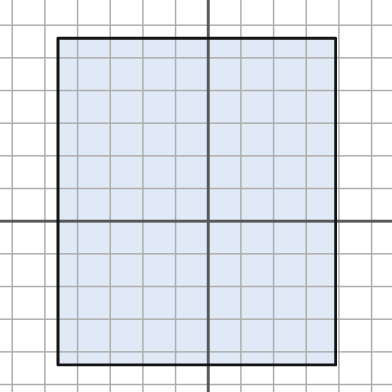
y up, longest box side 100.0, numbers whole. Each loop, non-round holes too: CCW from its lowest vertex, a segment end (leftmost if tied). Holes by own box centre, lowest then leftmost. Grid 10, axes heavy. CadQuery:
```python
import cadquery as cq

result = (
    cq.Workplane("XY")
    .moveTo(-46.0, -44.0)
    .lineTo(39.0, -44.0)
    .lineTo(39.0, 56.0)
    .lineTo(-46.0, 56.0)
    .close()
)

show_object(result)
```